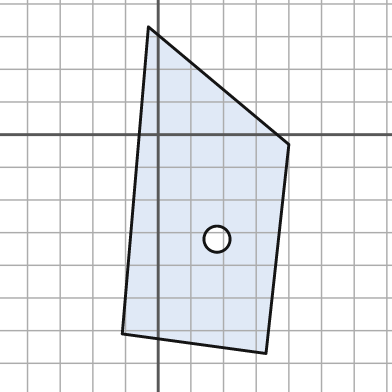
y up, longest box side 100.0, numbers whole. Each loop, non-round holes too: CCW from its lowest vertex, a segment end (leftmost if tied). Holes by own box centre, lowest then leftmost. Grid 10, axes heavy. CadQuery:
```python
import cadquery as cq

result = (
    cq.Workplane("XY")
    .moveTo(33.0, -67.0)
    .lineTo(40.0, -3.0)
    .lineTo(-3.0, 33.0)
    .lineTo(-11.0, -61.0)
    .close()
    .moveTo(18.0, -32.0)
    .circle(4.0)
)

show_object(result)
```